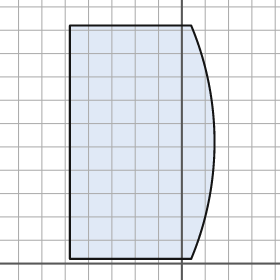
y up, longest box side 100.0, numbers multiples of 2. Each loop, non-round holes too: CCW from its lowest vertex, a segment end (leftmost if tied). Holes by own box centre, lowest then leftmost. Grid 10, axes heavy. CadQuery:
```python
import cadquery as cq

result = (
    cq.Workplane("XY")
    .moveTo(-48.0, 2.0)
    .lineTo(4.0, 2.0)
    .threePointArc((14.0, 52.0), (4.0, 102.0))
    .lineTo(-48.0, 102.0)
    .close()
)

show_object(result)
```